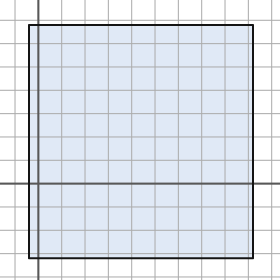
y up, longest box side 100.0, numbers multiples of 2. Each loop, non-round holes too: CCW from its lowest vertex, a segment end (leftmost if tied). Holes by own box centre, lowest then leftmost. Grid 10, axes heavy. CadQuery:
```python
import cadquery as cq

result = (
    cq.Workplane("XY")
    .moveTo(-4.0, -32.0)
    .lineTo(92.0, -32.0)
    .lineTo(92.0, 68.0)
    .lineTo(-4.0, 68.0)
    .close()
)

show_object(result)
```